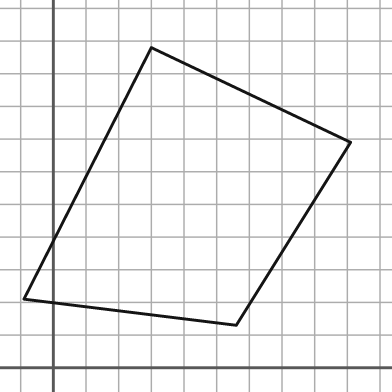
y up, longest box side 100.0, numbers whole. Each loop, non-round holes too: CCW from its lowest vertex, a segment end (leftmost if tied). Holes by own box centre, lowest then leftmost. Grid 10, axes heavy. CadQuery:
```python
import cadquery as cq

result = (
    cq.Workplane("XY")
    .moveTo(56.0, 13.0)
    .lineTo(91.0, 69.0)
    .lineTo(30.0, 98.0)
    .lineTo(-9.0, 21.0)
    .close()
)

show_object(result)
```